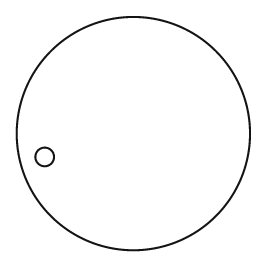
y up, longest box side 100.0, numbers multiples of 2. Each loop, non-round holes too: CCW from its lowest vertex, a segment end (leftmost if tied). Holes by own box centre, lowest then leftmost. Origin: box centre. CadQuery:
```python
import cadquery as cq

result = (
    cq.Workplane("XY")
    .moveTo(0.0, 0.0)
    .circle(50.0)
    .moveTo(-38.0, -10.0)
    .circle(4.0)
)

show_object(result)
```